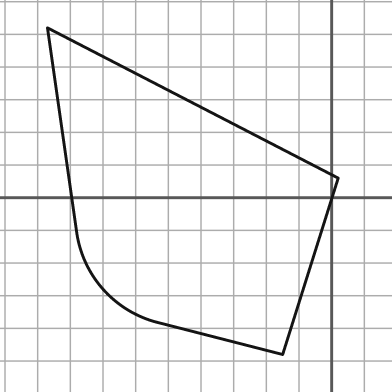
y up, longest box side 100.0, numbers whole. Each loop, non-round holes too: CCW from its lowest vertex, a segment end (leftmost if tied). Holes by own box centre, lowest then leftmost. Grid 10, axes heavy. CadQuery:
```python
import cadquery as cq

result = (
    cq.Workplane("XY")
    .moveTo(-15.0, -48.0)
    .lineTo(2.0, 6.0)
    .lineTo(-87.0, 52.0)
    .lineTo(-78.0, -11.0)
    .threePointArc((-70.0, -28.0), (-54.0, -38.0))
    .close()
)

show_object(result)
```